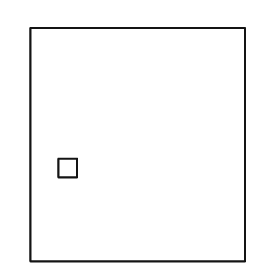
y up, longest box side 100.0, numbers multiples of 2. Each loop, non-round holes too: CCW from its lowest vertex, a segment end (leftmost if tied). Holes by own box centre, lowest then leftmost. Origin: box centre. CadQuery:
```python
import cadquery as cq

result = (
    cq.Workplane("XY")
    .moveTo(-46.0, -50.0)
    .lineTo(46.0, -50.0)
    .lineTo(46.0, 50.0)
    .lineTo(-46.0, 50.0)
    .close()
    .moveTo(-34.0, -14.0)
    .lineTo(-26.0, -14.0)
    .lineTo(-26.0, -6.0)
    .lineTo(-34.0, -6.0)
    .close()
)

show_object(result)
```